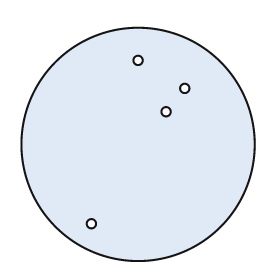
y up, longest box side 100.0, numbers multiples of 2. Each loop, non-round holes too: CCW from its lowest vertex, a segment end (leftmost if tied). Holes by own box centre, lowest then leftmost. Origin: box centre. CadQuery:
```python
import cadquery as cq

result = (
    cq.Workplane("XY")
    .moveTo(0.0, 0.0)
    .circle(50.0)
    .moveTo(-20.0, -34.0)
    .circle(2.0)
    .moveTo(12.0, 14.0)
    .circle(2.0)
    .moveTo(20.0, 24.0)
    .circle(2.0)
    .moveTo(0.0, 36.0)
    .circle(2.0)
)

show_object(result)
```